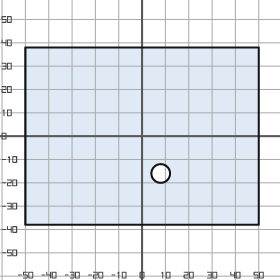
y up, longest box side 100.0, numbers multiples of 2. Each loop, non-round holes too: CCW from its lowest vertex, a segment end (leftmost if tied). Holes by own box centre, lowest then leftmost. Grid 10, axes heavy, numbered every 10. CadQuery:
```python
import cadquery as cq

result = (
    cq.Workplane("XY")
    .moveTo(-50.0, -38.0)
    .lineTo(50.0, -38.0)
    .lineTo(50.0, 38.0)
    .lineTo(-50.0, 38.0)
    .close()
    .moveTo(8.0, -16.0)
    .circle(4.0)
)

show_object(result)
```